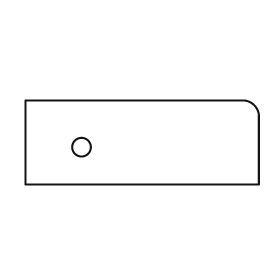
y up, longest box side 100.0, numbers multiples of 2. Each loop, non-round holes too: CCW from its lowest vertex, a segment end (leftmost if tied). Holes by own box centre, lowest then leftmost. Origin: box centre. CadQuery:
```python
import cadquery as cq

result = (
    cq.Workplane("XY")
    .moveTo(-50.0, -18.0)
    .lineTo(50.0, -18.0)
    .lineTo(50.0, 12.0)
    .threePointArc((48.0, 16.0), (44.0, 18.0))
    .lineTo(-50.0, 18.0)
    .close()
    .moveTo(-26.0, -2.0)
    .circle(4.0)
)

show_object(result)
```